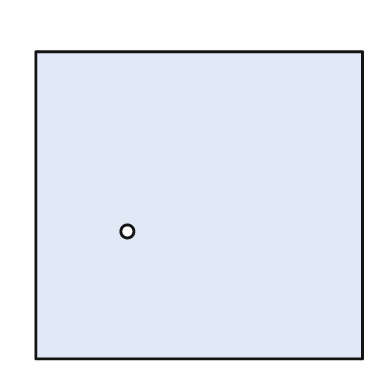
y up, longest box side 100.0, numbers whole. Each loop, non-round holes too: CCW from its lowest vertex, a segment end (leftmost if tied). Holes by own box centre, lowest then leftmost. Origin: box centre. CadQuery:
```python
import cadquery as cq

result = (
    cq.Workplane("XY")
    .moveTo(-50.0, -47.0)
    .lineTo(50.0, -47.0)
    .lineTo(50.0, 47.0)
    .lineTo(-50.0, 47.0)
    .close()
    .moveTo(-22.0, -8.0)
    .circle(2.0)
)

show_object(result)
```